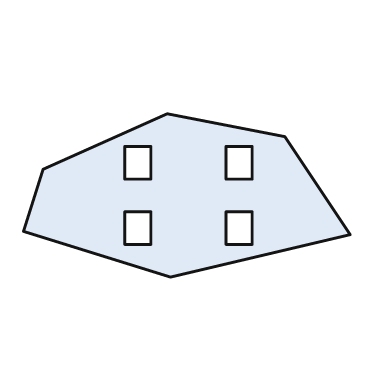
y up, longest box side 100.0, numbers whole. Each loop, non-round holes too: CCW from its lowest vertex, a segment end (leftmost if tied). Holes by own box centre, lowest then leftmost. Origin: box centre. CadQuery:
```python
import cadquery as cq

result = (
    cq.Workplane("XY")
    .moveTo(-5.0, -25.0)
    .lineTo(50.0, -12.0)
    .lineTo(30.0, 18.0)
    .lineTo(-6.0, 25.0)
    .lineTo(-44.0, 8.0)
    .lineTo(-50.0, -11.0)
    .close()
    .moveTo(-19.0, -15.0)
    .lineTo(-11.0, -15.0)
    .lineTo(-11.0, -5.0)
    .lineTo(-19.0, -5.0)
    .close()
    .moveTo(12.0, -15.0)
    .lineTo(20.0, -15.0)
    .lineTo(20.0, -5.0)
    .lineTo(12.0, -5.0)
    .close()
    .moveTo(-19.0, 5.0)
    .lineTo(-11.0, 5.0)
    .lineTo(-11.0, 15.0)
    .lineTo(-19.0, 15.0)
    .close()
    .moveTo(12.0, 5.0)
    .lineTo(20.0, 5.0)
    .lineTo(20.0, 15.0)
    .lineTo(12.0, 15.0)
    .close()
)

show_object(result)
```